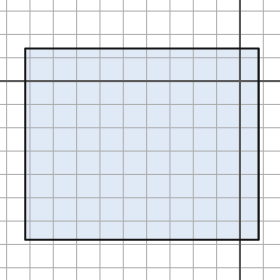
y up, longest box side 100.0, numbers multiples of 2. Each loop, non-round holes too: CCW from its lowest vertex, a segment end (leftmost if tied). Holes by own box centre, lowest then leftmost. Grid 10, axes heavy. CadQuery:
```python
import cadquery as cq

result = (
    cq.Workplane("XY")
    .moveTo(-92.0, -68.0)
    .lineTo(8.0, -68.0)
    .lineTo(8.0, 14.0)
    .lineTo(-92.0, 14.0)
    .close()
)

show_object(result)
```